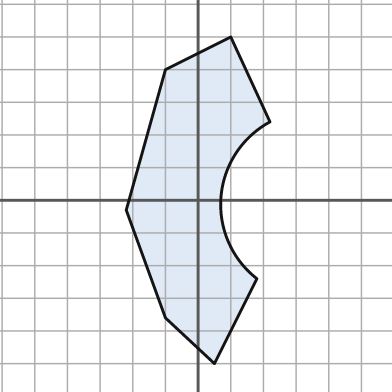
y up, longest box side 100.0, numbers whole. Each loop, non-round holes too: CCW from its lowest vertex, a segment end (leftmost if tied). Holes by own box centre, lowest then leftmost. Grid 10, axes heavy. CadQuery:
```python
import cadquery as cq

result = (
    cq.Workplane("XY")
    .moveTo(5.0, -50.0)
    .lineTo(18.0, -24.0)
    .threePointArc((7.0, 1.0), (22.0, 24.0))
    .lineTo(10.0, 50.0)
    .lineTo(-10.0, 40.0)
    .lineTo(-22.0, -3.0)
    .lineTo(-10.0, -36.0)
    .close()
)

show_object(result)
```